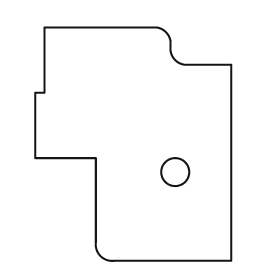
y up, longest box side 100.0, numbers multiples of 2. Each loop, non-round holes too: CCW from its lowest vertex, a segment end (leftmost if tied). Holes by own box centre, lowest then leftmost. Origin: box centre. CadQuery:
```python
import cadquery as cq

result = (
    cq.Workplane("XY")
    .moveTo(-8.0, -50.0)
    .lineTo(42.0, -50.0)
    .lineTo(42.0, 34.0)
    .lineTo(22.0, 34.0)
    .threePointArc((18.0, 36.0), (16.0, 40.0))
    .lineTo(16.0, 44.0)
    .threePointArc((14.0, 48.0), (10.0, 50.0))
    .lineTo(-38.0, 50.0)
    .lineTo(-38.0, 22.0)
    .lineTo(-42.0, 22.0)
    .lineTo(-42.0, -6.0)
    .lineTo(-16.0, -6.0)
    .lineTo(-16.0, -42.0)
    .threePointArc((-14.0, -48.0), (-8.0, -50.0))
    .close()
    .moveTo(18.0, -12.0)
    .circle(6.0)
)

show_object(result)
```